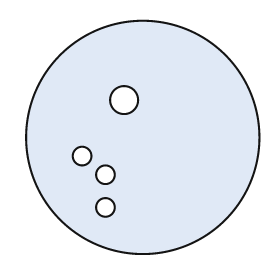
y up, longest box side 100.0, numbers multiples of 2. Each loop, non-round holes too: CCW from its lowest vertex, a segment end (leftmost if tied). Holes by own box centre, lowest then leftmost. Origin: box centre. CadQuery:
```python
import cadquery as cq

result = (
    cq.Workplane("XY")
    .moveTo(0.0, 0.0)
    .circle(50.0)
    .moveTo(-16.0, -30.0)
    .circle(4.0)
    .moveTo(-16.0, -16.0)
    .circle(4.0)
    .moveTo(-26.0, -8.0)
    .circle(4.0)
    .moveTo(-8.0, 16.0)
    .circle(6.0)
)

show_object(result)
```